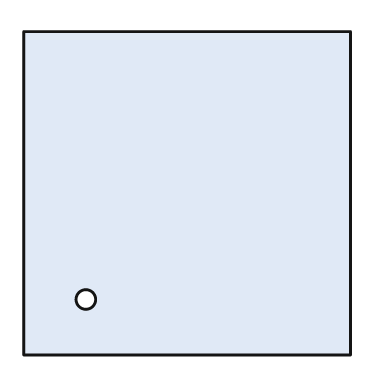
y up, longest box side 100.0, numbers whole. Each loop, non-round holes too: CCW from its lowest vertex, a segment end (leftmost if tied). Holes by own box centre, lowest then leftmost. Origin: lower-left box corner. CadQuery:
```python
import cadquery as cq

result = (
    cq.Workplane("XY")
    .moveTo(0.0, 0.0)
    .lineTo(100.0, 0.0)
    .lineTo(100.0, 99.0)
    .lineTo(0.0, 99.0)
    .close()
    .moveTo(19.0, 17.0)
    .circle(3.0)
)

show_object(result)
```